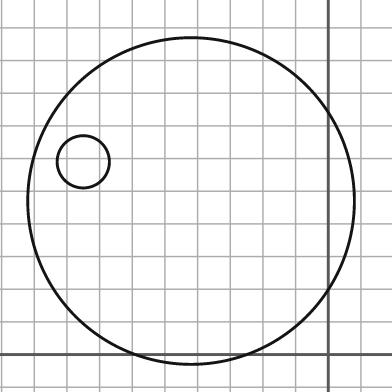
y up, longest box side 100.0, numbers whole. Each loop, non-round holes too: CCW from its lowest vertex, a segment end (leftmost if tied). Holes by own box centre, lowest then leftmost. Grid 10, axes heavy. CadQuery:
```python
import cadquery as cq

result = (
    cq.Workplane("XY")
    .moveTo(-42.0, 47.0)
    .circle(50.0)
    .moveTo(-75.0, 59.0)
    .circle(8.0)
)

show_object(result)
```